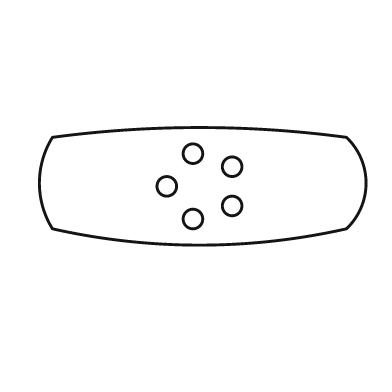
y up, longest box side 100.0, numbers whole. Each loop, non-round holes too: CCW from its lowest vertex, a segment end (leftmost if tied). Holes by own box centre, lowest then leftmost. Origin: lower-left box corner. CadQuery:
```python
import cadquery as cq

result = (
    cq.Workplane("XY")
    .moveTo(4.0, 5.0)
    .threePointArc((49.0, 0.0), (94.0, 5.0))
    .threePointArc((100.0, 19.0), (94.0, 33.0))
    .threePointArc((49.0, 36.0), (4.0, 33.0))
    .threePointArc((0.0, 19.0), (4.0, 5.0))
    .close()
    .moveTo(47.0, 8.0)
    .circle(3.0)
    .moveTo(59.0, 12.0)
    .circle(3.0)
    .moveTo(39.0, 18.0)
    .circle(3.0)
    .moveTo(59.0, 24.0)
    .circle(3.0)
    .moveTo(47.0, 28.0)
    .circle(3.0)
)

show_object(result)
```